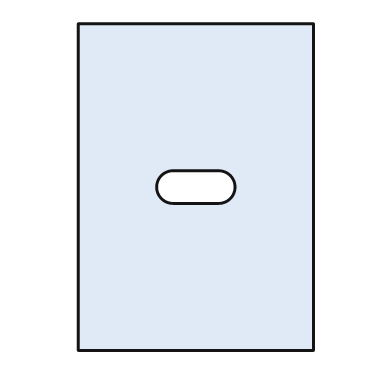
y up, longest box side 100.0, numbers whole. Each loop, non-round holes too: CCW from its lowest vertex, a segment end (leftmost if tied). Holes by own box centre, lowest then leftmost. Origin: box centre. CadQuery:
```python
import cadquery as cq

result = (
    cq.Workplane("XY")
    .moveTo(-36.0, -50.0)
    .lineTo(36.0, -50.0)
    .lineTo(36.0, 50.0)
    .lineTo(-36.0, 50.0)
    .close()
    .moveTo(-7.0, -5.0)
    .lineTo(7.0, -5.0)
    .threePointArc((12.0, 0.0), (7.0, 5.0))
    .lineTo(-7.0, 5.0)
    .threePointArc((-12.0, 0.0), (-7.0, -5.0))
    .close()
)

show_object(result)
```